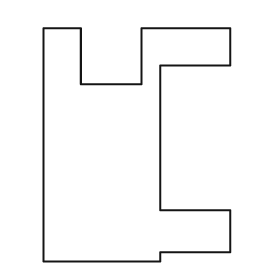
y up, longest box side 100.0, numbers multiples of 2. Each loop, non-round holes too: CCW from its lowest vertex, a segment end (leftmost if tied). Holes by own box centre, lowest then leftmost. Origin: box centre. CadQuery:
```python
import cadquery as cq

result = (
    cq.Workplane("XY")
    .moveTo(-40.0, -50.0)
    .lineTo(10.0, -50.0)
    .lineTo(10.0, -46.0)
    .lineTo(40.0, -46.0)
    .lineTo(40.0, -28.0)
    .lineTo(10.0, -28.0)
    .lineTo(10.0, 34.0)
    .lineTo(40.0, 34.0)
    .lineTo(40.0, 50.0)
    .lineTo(2.0, 50.0)
    .lineTo(2.0, 26.0)
    .lineTo(-24.0, 26.0)
    .lineTo(-24.0, 50.0)
    .lineTo(-40.0, 50.0)
    .close()
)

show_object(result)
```